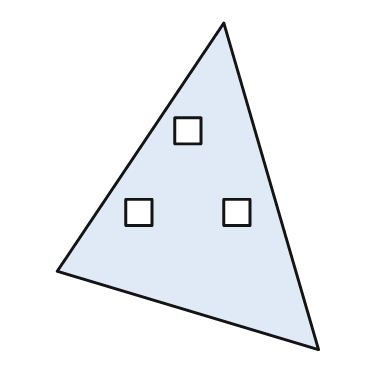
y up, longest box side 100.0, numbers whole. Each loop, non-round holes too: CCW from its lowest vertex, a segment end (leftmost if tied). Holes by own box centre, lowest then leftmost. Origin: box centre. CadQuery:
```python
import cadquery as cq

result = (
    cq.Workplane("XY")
    .moveTo(40.0, -50.0)
    .lineTo(11.0, 50.0)
    .lineTo(-40.0, -26.0)
    .close()
    .moveTo(-19.0, -12.0)
    .lineTo(-11.0, -12.0)
    .lineTo(-11.0, -4.0)
    .lineTo(-19.0, -4.0)
    .close()
    .moveTo(11.0, -12.0)
    .lineTo(19.0, -12.0)
    .lineTo(19.0, -4.0)
    .lineTo(11.0, -4.0)
    .close()
    .moveTo(-4.0, 13.0)
    .lineTo(4.0, 13.0)
    .lineTo(4.0, 21.0)
    .lineTo(-4.0, 21.0)
    .close()
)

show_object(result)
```